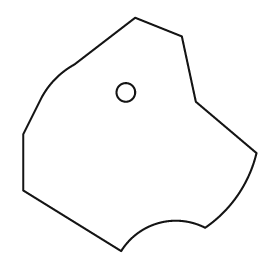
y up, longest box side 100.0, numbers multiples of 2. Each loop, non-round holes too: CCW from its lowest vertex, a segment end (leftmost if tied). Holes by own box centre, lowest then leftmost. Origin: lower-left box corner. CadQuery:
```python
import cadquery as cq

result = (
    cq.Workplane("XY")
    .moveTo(42.0, 0.0)
    .threePointArc((58.0, 12.0), (78.0, 10.0))
    .threePointArc((92.0, 24.0), (100.0, 42.0))
    .lineTo(74.0, 64.0)
    .lineTo(68.0, 92.0)
    .lineTo(48.0, 100.0)
    .lineTo(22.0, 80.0)
    .threePointArc((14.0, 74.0), (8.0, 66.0))
    .lineTo(0.0, 50.0)
    .lineTo(0.0, 26.0)
    .close()
    .moveTo(44.0, 68.0)
    .circle(4.0)
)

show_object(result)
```